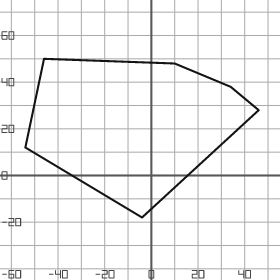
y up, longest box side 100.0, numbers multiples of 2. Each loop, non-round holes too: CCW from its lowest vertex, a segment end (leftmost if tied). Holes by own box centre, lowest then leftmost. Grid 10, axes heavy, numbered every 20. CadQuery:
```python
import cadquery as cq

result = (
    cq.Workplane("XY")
    .moveTo(-4.0, -18.0)
    .lineTo(46.0, 28.0)
    .lineTo(34.0, 38.0)
    .lineTo(10.0, 48.0)
    .lineTo(-46.0, 50.0)
    .lineTo(-54.0, 12.0)
    .close()
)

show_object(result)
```